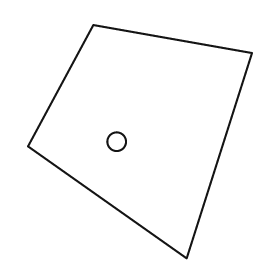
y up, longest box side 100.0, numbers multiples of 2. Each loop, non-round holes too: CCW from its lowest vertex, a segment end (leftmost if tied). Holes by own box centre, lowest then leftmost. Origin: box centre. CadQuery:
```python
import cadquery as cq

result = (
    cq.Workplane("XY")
    .moveTo(20.0, -50.0)
    .lineTo(48.0, 38.0)
    .lineTo(-20.0, 50.0)
    .lineTo(-48.0, -2.0)
    .close()
    .moveTo(-10.0, 0.0)
    .circle(4.0)
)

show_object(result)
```